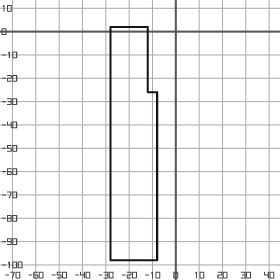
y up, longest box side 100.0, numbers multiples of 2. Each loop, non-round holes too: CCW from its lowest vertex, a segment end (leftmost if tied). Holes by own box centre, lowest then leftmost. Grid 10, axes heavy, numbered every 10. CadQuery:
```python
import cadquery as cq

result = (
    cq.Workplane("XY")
    .moveTo(-28.0, -98.0)
    .lineTo(-8.0, -98.0)
    .lineTo(-8.0, -26.0)
    .lineTo(-12.0, -26.0)
    .lineTo(-12.0, 2.0)
    .lineTo(-28.0, 2.0)
    .close()
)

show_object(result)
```